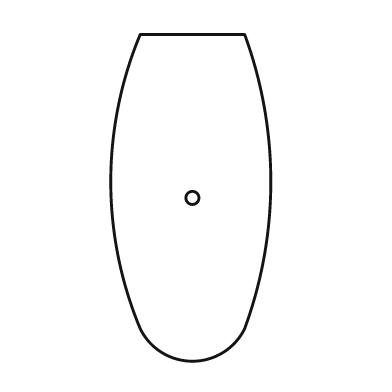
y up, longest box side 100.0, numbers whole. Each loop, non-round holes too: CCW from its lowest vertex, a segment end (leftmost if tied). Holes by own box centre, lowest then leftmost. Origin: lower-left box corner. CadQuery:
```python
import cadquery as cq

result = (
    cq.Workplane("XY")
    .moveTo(9.0, 10.0)
    .threePointArc((25.0, 0.0), (41.0, 10.0))
    .threePointArc((49.0, 55.0), (41.0, 100.0))
    .lineTo(9.0, 100.0)
    .threePointArc((0.0, 55.0), (9.0, 10.0))
    .close()
    .moveTo(25.0, 50.0)
    .circle(2.0)
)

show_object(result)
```